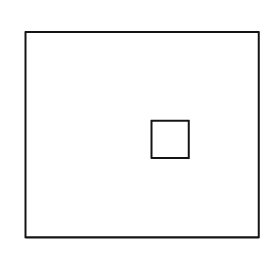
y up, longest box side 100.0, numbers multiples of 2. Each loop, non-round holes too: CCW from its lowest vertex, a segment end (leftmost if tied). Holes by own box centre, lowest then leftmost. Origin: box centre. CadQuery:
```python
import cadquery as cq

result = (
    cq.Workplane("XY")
    .moveTo(-50.0, -44.0)
    .lineTo(50.0, -44.0)
    .lineTo(50.0, 44.0)
    .lineTo(-50.0, 44.0)
    .close()
    .moveTo(4.0, -10.0)
    .lineTo(20.0, -10.0)
    .lineTo(20.0, 6.0)
    .lineTo(4.0, 6.0)
    .close()
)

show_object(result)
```